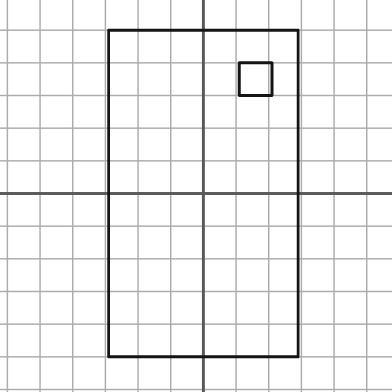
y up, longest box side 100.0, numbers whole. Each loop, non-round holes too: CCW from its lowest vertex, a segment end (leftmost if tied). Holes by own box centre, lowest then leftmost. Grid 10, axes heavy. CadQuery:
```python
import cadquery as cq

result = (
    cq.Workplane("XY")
    .moveTo(-29.0, -50.0)
    .lineTo(29.0, -50.0)
    .lineTo(29.0, 50.0)
    .lineTo(-29.0, 50.0)
    .close()
    .moveTo(11.0, 30.0)
    .lineTo(21.0, 30.0)
    .lineTo(21.0, 40.0)
    .lineTo(11.0, 40.0)
    .close()
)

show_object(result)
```